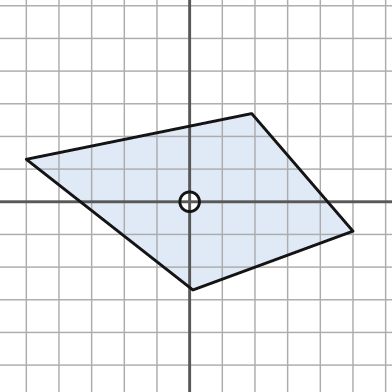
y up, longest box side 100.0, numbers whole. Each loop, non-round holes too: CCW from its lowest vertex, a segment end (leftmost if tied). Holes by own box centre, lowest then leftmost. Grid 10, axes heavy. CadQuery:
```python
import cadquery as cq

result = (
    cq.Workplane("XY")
    .moveTo(1.0, -27.0)
    .lineTo(50.0, -9.0)
    .lineTo(19.0, 27.0)
    .lineTo(-50.0, 13.0)
    .close()
    .moveTo(0.0, 0.0)
    .circle(3.0)
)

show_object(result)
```